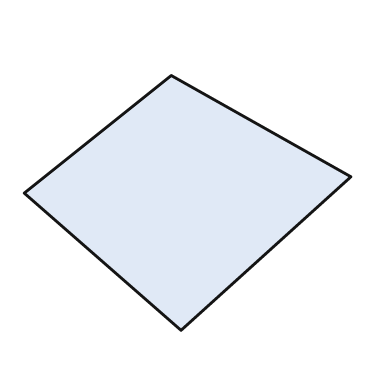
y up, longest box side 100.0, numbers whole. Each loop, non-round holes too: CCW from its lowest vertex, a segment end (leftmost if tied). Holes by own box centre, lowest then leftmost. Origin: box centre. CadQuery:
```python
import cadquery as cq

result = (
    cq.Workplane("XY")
    .moveTo(-2.0, -39.0)
    .lineTo(50.0, 8.0)
    .lineTo(-5.0, 39.0)
    .lineTo(-50.0, 3.0)
    .close()
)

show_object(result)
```